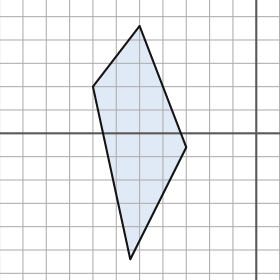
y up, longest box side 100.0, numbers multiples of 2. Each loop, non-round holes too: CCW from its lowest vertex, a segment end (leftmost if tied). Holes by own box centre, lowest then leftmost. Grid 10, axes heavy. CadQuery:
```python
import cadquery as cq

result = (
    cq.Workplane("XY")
    .moveTo(-54.0, -54.0)
    .lineTo(-30.0, -6.0)
    .lineTo(-50.0, 46.0)
    .lineTo(-70.0, 20.0)
    .close()
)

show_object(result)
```